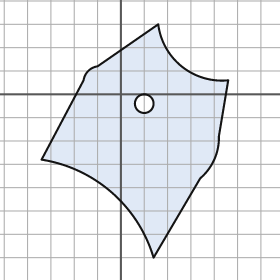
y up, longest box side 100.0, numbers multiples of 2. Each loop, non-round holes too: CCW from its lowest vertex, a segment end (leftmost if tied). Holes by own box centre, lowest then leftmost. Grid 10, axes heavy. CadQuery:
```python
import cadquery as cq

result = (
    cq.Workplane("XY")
    .moveTo(14.0, -70.0)
    .lineTo(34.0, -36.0)
    .threePointArc((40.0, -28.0), (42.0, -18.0))
    .lineTo(46.0, 6.0)
    .threePointArc((26.0, 12.0), (16.0, 30.0))
    .lineTo(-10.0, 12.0)
    .threePointArc((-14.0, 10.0), (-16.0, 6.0))
    .lineTo(-34.0, -28.0)
    .threePointArc((-4.0, -42.0), (14.0, -70.0))
    .close()
    .moveTo(10.0, -4.0)
    .circle(4.0)
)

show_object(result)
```